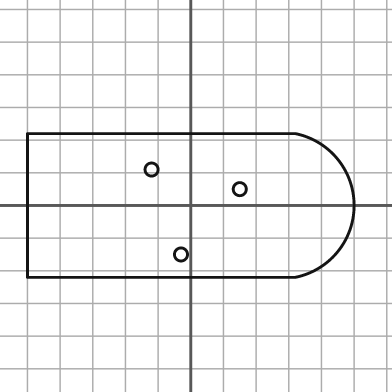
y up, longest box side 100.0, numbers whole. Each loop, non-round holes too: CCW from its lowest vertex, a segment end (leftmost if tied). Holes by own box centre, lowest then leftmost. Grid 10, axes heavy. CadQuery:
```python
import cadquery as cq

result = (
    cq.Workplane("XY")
    .moveTo(-50.0, -22.0)
    .lineTo(32.0, -22.0)
    .threePointArc((50.0, 0.0), (32.0, 22.0))
    .lineTo(-50.0, 22.0)
    .close()
    .moveTo(-3.0, -15.0)
    .circle(2.0)
    .moveTo(15.0, 5.0)
    .circle(2.0)
    .moveTo(-12.0, 11.0)
    .circle(2.0)
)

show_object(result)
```